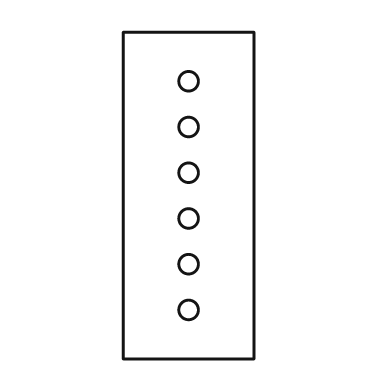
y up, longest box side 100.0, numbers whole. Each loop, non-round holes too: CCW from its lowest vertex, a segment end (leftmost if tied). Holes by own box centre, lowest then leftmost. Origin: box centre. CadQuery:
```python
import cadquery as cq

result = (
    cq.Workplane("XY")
    .moveTo(-20.0, -50.0)
    .lineTo(20.0, -50.0)
    .lineTo(20.0, 50.0)
    .lineTo(-20.0, 50.0)
    .close()
    .moveTo(0.0, -35.0)
    .circle(3.0)
    .moveTo(0.0, -21.0)
    .circle(3.0)
    .moveTo(0.0, -7.0)
    .circle(3.0)
    .moveTo(0.0, 7.0)
    .circle(3.0)
    .moveTo(0.0, 21.0)
    .circle(3.0)
    .moveTo(0.0, 35.0)
    .circle(3.0)
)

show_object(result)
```